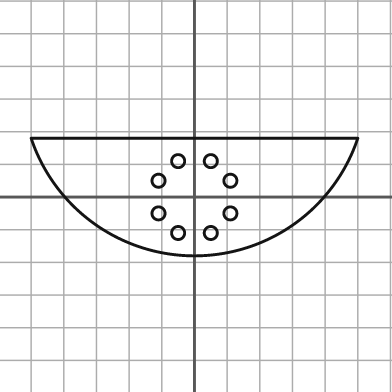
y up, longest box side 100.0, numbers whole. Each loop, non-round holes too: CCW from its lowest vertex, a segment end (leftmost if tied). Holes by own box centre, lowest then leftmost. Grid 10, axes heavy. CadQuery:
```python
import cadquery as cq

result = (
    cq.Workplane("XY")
    .moveTo(-50.0, 18.0)
    .threePointArc((0.0, -18.0), (50.0, 18.0))
    .close()
    .moveTo(-5.0, -11.0)
    .circle(2.0)
    .moveTo(5.0, -11.0)
    .circle(2.0)
    .moveTo(-11.0, -5.0)
    .circle(2.0)
    .moveTo(11.0, -5.0)
    .circle(2.0)
    .moveTo(-11.0, 5.0)
    .circle(2.0)
    .moveTo(11.0, 5.0)
    .circle(2.0)
    .moveTo(-5.0, 11.0)
    .circle(2.0)
    .moveTo(5.0, 11.0)
    .circle(2.0)
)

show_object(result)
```